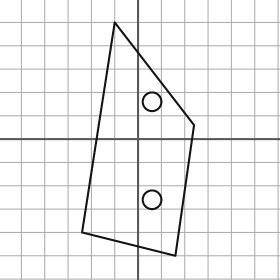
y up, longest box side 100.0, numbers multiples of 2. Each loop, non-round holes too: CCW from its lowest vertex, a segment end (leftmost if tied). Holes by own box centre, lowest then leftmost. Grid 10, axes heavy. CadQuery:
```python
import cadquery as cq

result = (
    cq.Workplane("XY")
    .moveTo(16.0, -50.0)
    .lineTo(24.0, 6.0)
    .lineTo(-10.0, 50.0)
    .lineTo(-24.0, -40.0)
    .close()
    .moveTo(6.0, -26.0)
    .circle(4.0)
    .moveTo(6.0, 16.0)
    .circle(4.0)
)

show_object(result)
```